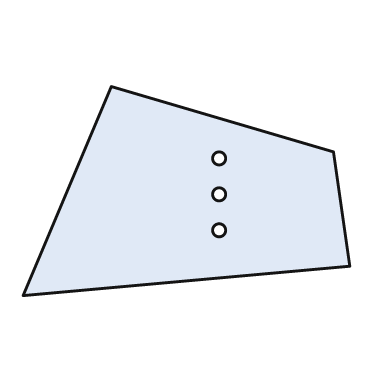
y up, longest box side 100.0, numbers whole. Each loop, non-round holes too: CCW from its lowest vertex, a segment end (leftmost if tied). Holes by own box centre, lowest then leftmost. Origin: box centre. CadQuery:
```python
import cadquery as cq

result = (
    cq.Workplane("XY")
    .moveTo(-50.0, -32.0)
    .lineTo(50.0, -23.0)
    .lineTo(45.0, 12.0)
    .lineTo(-23.0, 32.0)
    .close()
    .moveTo(10.0, -12.0)
    .circle(2.0)
    .moveTo(10.0, -1.0)
    .circle(2.0)
    .moveTo(10.0, 10.0)
    .circle(2.0)
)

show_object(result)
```